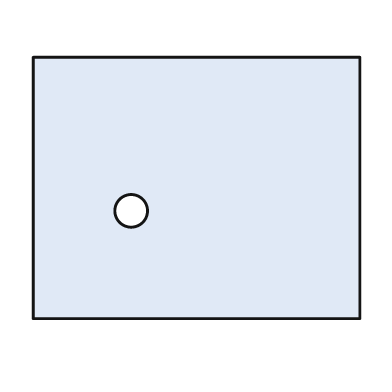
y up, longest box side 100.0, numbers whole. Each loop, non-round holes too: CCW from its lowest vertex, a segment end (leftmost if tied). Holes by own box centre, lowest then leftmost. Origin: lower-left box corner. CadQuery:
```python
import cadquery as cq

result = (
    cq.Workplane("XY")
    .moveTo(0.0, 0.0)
    .lineTo(100.0, 0.0)
    .lineTo(100.0, 80.0)
    .lineTo(0.0, 80.0)
    .close()
    .moveTo(30.0, 33.0)
    .circle(5.0)
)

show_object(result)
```